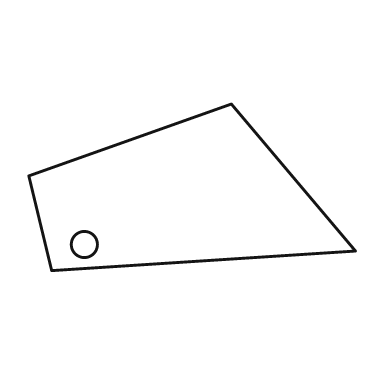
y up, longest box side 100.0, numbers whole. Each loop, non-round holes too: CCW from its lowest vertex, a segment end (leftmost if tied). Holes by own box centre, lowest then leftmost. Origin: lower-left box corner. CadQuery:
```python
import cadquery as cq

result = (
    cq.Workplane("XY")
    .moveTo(7.0, 0.0)
    .lineTo(100.0, 6.0)
    .lineTo(62.0, 51.0)
    .lineTo(0.0, 29.0)
    .close()
    .moveTo(17.0, 8.0)
    .circle(4.0)
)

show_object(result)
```